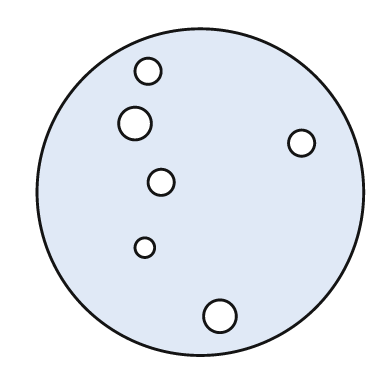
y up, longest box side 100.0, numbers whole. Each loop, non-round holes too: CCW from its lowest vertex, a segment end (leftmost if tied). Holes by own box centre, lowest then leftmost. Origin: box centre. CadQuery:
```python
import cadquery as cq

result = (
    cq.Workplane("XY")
    .moveTo(0.0, 0.0)
    .circle(50.0)
    .moveTo(6.0, -38.0)
    .circle(5.0)
    .moveTo(-17.0, -17.0)
    .circle(3.0)
    .moveTo(-12.0, 3.0)
    .circle(4.0)
    .moveTo(31.0, 15.0)
    .circle(4.0)
    .moveTo(-20.0, 21.0)
    .circle(5.0)
    .moveTo(-16.0, 37.0)
    .circle(4.0)
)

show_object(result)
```